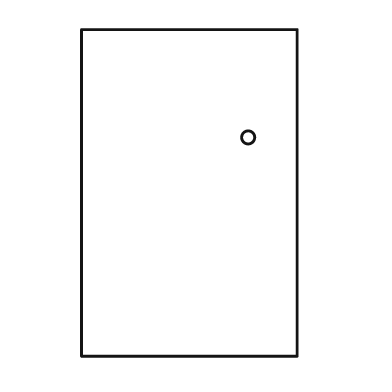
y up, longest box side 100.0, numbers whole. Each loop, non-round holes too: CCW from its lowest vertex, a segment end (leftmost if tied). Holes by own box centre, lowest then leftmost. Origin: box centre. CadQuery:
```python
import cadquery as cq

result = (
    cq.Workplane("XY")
    .moveTo(-33.0, -50.0)
    .lineTo(33.0, -50.0)
    .lineTo(33.0, 50.0)
    .lineTo(-33.0, 50.0)
    .close()
    .moveTo(18.0, 17.0)
    .circle(2.0)
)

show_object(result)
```